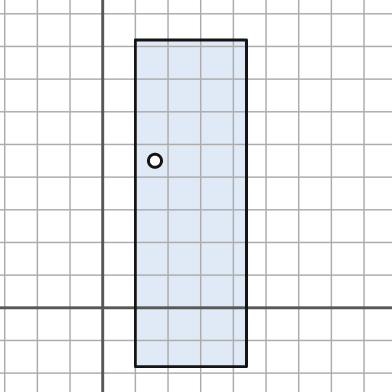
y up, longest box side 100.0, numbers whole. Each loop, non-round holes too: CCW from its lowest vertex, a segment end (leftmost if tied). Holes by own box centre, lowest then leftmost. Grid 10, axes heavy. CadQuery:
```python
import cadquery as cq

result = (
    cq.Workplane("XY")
    .moveTo(10.0, -18.0)
    .lineTo(44.0, -18.0)
    .lineTo(44.0, 82.0)
    .lineTo(10.0, 82.0)
    .close()
    .moveTo(16.0, 45.0)
    .circle(2.0)
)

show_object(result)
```